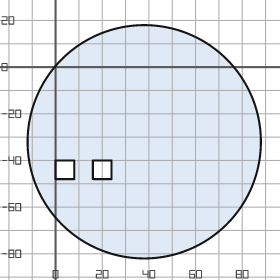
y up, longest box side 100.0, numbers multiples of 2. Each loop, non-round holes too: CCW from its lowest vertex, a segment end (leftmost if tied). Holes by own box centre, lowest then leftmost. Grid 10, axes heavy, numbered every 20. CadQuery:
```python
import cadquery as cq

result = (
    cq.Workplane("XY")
    .moveTo(38.0, -32.0)
    .circle(50.0)
    .moveTo(0.0, -48.0)
    .lineTo(8.0, -48.0)
    .lineTo(8.0, -40.0)
    .lineTo(0.0, -40.0)
    .close()
    .moveTo(16.0, -48.0)
    .lineTo(24.0, -48.0)
    .lineTo(24.0, -40.0)
    .lineTo(16.0, -40.0)
    .close()
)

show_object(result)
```